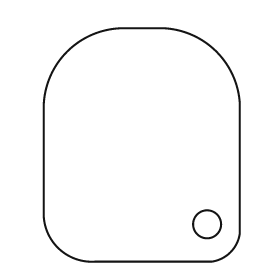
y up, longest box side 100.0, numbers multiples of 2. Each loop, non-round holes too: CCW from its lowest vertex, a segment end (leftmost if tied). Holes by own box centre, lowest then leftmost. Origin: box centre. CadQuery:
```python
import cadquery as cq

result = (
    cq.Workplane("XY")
    .moveTo(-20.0, -50.0)
    .lineTo(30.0, -50.0)
    .threePointArc((38.0, -46.0), (42.0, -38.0))
    .lineTo(42.0, 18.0)
    .threePointArc((32.0, 40.0), (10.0, 50.0))
    .lineTo(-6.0, 50.0)
    .threePointArc((-32.0, 40.0), (-42.0, 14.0))
    .lineTo(-42.0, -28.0)
    .threePointArc((-36.0, -44.0), (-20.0, -50.0))
    .close()
    .moveTo(28.0, -34.0)
    .circle(6.0)
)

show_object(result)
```